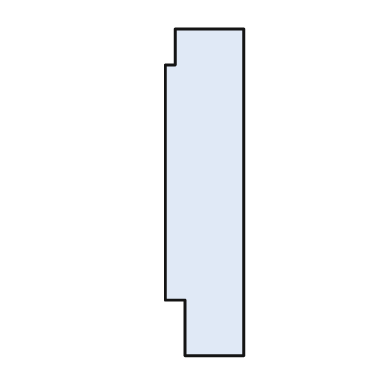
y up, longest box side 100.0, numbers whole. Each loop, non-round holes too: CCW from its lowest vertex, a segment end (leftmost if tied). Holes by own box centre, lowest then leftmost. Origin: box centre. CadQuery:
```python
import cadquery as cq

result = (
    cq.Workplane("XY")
    .moveTo(-6.0, -50.0)
    .lineTo(12.0, -50.0)
    .lineTo(12.0, 50.0)
    .lineTo(-9.0, 50.0)
    .lineTo(-9.0, 39.0)
    .lineTo(-12.0, 39.0)
    .lineTo(-12.0, -33.0)
    .lineTo(-6.0, -33.0)
    .close()
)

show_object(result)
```